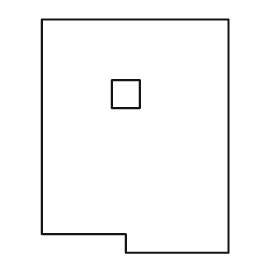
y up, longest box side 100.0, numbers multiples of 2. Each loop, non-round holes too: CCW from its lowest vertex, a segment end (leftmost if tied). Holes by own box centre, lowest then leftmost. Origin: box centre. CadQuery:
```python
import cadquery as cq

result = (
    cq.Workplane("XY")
    .moveTo(-4.0, -50.0)
    .lineTo(40.0, -50.0)
    .lineTo(40.0, 50.0)
    .lineTo(-40.0, 50.0)
    .lineTo(-40.0, -42.0)
    .lineTo(-4.0, -42.0)
    .close()
    .moveTo(-10.0, 12.0)
    .lineTo(2.0, 12.0)
    .lineTo(2.0, 24.0)
    .lineTo(-10.0, 24.0)
    .close()
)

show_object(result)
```